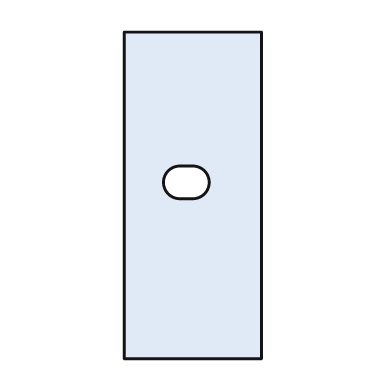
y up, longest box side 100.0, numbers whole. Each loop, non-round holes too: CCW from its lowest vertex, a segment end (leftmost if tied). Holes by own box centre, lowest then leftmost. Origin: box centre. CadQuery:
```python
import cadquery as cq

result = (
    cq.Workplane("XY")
    .moveTo(-21.0, -50.0)
    .lineTo(21.0, -50.0)
    .lineTo(21.0, 50.0)
    .lineTo(-21.0, 50.0)
    .close()
    .moveTo(-4.0, -1.0)
    .lineTo(0.0, -1.0)
    .threePointArc((5.0, 4.0), (0.0, 9.0))
    .lineTo(-4.0, 9.0)
    .threePointArc((-9.0, 4.0), (-4.0, -1.0))
    .close()
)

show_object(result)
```